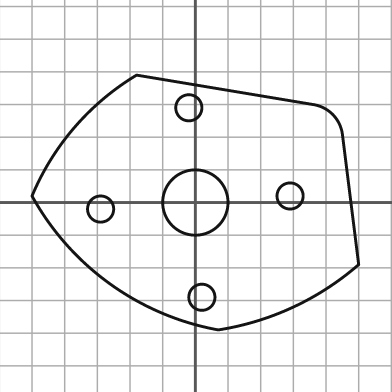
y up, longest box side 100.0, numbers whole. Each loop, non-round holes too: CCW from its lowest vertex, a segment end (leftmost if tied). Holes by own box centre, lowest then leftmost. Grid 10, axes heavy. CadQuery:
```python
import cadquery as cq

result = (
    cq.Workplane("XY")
    .moveTo(7.0, -39.0)
    .threePointArc((30.0, -32.0), (50.0, -19.0))
    .lineTo(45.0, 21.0)
    .threePointArc((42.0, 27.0), (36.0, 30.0))
    .lineTo(-18.0, 39.0)
    .threePointArc((-37.0, 23.0), (-50.0, 2.0))
    .threePointArc((-26.0, -25.0), (7.0, -39.0))
    .close()
    .moveTo(2.0, -29.0)
    .circle(4.0)
    .moveTo(-29.0, -2.0)
    .circle(4.0)
    .moveTo(0.0, 0.0)
    .circle(10.0)
    .moveTo(29.0, 2.0)
    .circle(4.0)
    .moveTo(-2.0, 29.0)
    .circle(4.0)
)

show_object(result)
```